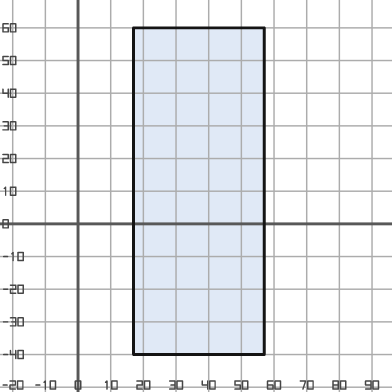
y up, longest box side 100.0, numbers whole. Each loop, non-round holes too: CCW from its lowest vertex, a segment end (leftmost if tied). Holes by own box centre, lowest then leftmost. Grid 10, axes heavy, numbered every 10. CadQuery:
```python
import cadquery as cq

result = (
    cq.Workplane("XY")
    .moveTo(17.0, -40.0)
    .lineTo(57.0, -40.0)
    .lineTo(57.0, 60.0)
    .lineTo(17.0, 60.0)
    .close()
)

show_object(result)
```